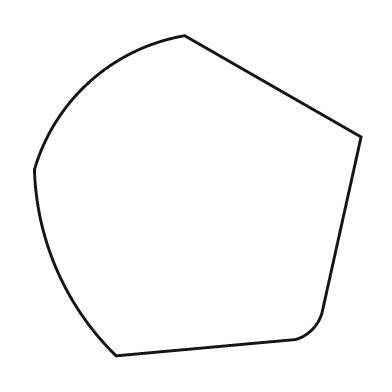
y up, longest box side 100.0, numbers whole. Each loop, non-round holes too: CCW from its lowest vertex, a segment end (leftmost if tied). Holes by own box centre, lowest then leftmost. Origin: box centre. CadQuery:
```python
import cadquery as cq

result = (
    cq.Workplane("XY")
    .moveTo(-25.0, -49.0)
    .lineTo(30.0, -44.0)
    .threePointArc((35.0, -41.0), (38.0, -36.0))
    .lineTo(50.0, 18.0)
    .lineTo(-4.0, 49.0)
    .threePointArc((-33.0, 35.0), (-50.0, 8.0))
    .threePointArc((-43.0, -23.0), (-25.0, -49.0))
    .close()
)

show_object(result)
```